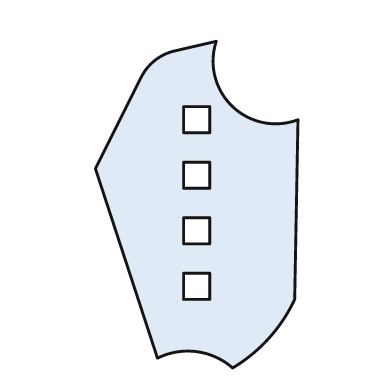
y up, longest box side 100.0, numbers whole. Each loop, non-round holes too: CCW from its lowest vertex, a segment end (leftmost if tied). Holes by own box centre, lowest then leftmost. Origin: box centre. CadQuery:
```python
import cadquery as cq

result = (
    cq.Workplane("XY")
    .moveTo(11.0, -50.0)
    .threePointArc((22.0, -41.0), (30.0, -29.0))
    .lineTo(31.0, 26.0)
    .threePointArc((11.0, 30.0), (6.0, 50.0))
    .lineTo(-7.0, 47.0)
    .threePointArc((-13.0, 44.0), (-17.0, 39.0))
    .lineTo(-31.0, 11.0)
    .lineTo(-12.0, -47.0)
    .threePointArc((0.0, -45.0), (11.0, -50.0))
    .close()
    .moveTo(-4.0, -29.0)
    .lineTo(4.0, -29.0)
    .lineTo(4.0, -21.0)
    .lineTo(-4.0, -21.0)
    .close()
    .moveTo(-4.0, -12.0)
    .lineTo(4.0, -12.0)
    .lineTo(4.0, -4.0)
    .lineTo(-4.0, -4.0)
    .close()
    .moveTo(-4.0, 5.0)
    .lineTo(4.0, 5.0)
    .lineTo(4.0, 13.0)
    .lineTo(-4.0, 13.0)
    .close()
    .moveTo(-4.0, 22.0)
    .lineTo(4.0, 22.0)
    .lineTo(4.0, 30.0)
    .lineTo(-4.0, 30.0)
    .close()
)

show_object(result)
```